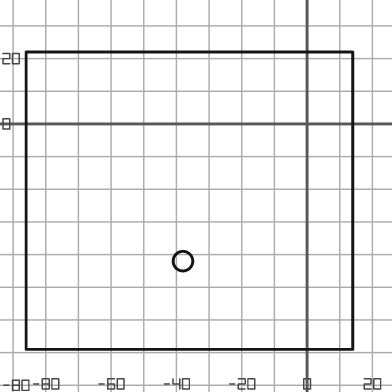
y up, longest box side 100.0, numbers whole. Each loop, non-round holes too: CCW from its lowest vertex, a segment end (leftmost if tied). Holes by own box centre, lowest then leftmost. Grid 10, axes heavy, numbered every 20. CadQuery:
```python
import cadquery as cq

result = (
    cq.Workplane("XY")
    .moveTo(-86.0, -69.0)
    .lineTo(14.0, -69.0)
    .lineTo(14.0, 22.0)
    .lineTo(-86.0, 22.0)
    .close()
    .moveTo(-38.0, -42.0)
    .circle(3.0)
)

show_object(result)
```